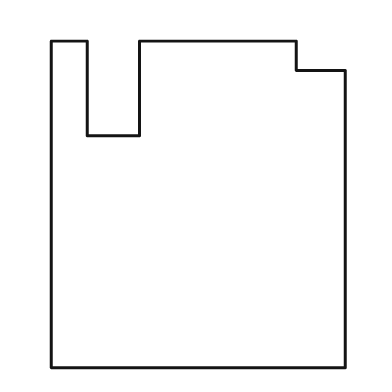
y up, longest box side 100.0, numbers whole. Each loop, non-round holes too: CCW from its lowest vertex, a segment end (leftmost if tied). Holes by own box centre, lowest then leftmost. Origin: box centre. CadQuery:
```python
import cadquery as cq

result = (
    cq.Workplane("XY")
    .moveTo(-45.0, -50.0)
    .lineTo(45.0, -50.0)
    .lineTo(45.0, 41.0)
    .lineTo(30.0, 41.0)
    .lineTo(30.0, 50.0)
    .lineTo(-18.0, 50.0)
    .lineTo(-18.0, 21.0)
    .lineTo(-34.0, 21.0)
    .lineTo(-34.0, 50.0)
    .lineTo(-45.0, 50.0)
    .close()
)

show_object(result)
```